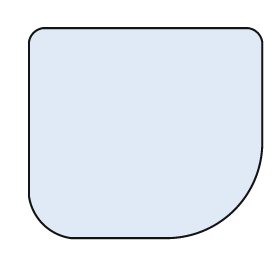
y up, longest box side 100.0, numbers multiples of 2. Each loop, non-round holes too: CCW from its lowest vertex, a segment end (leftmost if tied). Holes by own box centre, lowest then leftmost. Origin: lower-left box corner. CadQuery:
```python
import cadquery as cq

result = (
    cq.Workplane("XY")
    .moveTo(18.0, 0.0)
    .lineTo(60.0, 0.0)
    .threePointArc((88.0, 12.0), (100.0, 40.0))
    .lineTo(100.0, 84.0)
    .threePointArc((98.0, 88.0), (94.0, 90.0))
    .lineTo(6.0, 90.0)
    .threePointArc((2.0, 88.0), (0.0, 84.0))
    .lineTo(0.0, 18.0)
    .threePointArc((6.0, 6.0), (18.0, 0.0))
    .close()
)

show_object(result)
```